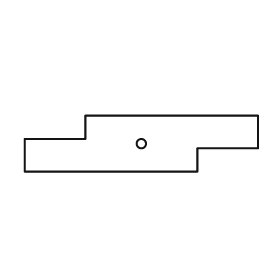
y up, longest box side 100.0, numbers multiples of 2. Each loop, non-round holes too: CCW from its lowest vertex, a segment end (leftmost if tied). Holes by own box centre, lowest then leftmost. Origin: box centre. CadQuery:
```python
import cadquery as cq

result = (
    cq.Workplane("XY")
    .moveTo(-50.0, -12.0)
    .lineTo(24.0, -12.0)
    .lineTo(24.0, -2.0)
    .lineTo(50.0, -2.0)
    .lineTo(50.0, 12.0)
    .lineTo(-24.0, 12.0)
    .lineTo(-24.0, 2.0)
    .lineTo(-50.0, 2.0)
    .close()
    .moveTo(0.0, 0.0)
    .circle(2.0)
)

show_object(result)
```